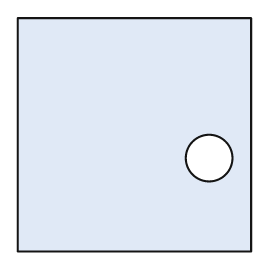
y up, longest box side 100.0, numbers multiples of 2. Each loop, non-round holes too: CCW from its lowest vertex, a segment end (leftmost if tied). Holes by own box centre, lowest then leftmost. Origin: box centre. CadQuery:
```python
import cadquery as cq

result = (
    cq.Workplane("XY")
    .moveTo(-50.0, -50.0)
    .lineTo(50.0, -50.0)
    .lineTo(50.0, 50.0)
    .lineTo(-50.0, 50.0)
    .close()
    .moveTo(32.0, -10.0)
    .circle(10.0)
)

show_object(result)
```